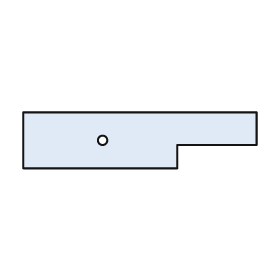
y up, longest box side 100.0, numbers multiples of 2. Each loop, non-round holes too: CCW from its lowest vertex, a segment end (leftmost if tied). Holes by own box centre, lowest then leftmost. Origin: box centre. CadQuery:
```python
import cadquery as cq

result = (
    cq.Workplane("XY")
    .moveTo(-50.0, -12.0)
    .lineTo(16.0, -12.0)
    .lineTo(16.0, -2.0)
    .lineTo(50.0, -2.0)
    .lineTo(50.0, 12.0)
    .lineTo(-50.0, 12.0)
    .close()
    .moveTo(-16.0, 0.0)
    .circle(2.0)
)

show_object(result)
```